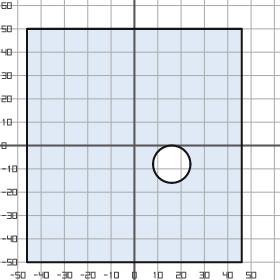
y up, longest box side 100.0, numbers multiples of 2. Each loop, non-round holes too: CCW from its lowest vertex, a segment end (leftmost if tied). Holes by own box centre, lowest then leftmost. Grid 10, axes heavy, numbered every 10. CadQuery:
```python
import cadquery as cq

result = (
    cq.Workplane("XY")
    .moveTo(-46.0, -50.0)
    .lineTo(46.0, -50.0)
    .lineTo(46.0, 50.0)
    .lineTo(-46.0, 50.0)
    .close()
    .moveTo(16.0, -8.0)
    .circle(8.0)
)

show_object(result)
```